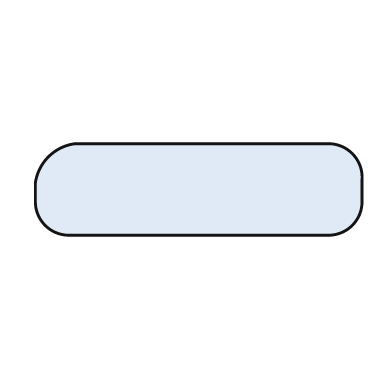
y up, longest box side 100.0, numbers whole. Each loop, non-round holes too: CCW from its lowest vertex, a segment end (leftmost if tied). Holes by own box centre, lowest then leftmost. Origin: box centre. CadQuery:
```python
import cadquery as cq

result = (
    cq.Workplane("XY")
    .moveTo(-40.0, -14.0)
    .lineTo(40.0, -14.0)
    .threePointArc((47.0, -11.0), (50.0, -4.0))
    .lineTo(50.0, 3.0)
    .threePointArc((47.0, 11.0), (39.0, 14.0))
    .lineTo(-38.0, 14.0)
    .threePointArc((-46.0, 10.0), (-50.0, 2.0))
    .lineTo(-50.0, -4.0)
    .threePointArc((-47.0, -11.0), (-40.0, -14.0))
    .close()
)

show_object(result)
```